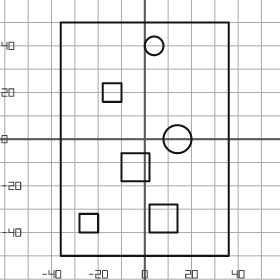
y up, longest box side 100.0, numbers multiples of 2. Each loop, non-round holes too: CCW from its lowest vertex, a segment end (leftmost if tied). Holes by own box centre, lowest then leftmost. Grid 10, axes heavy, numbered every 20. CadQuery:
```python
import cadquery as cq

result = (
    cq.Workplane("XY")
    .moveTo(-36.0, -50.0)
    .lineTo(36.0, -50.0)
    .lineTo(36.0, 50.0)
    .lineTo(-36.0, 50.0)
    .close()
    .moveTo(-28.0, -40.0)
    .lineTo(-20.0, -40.0)
    .lineTo(-20.0, -32.0)
    .lineTo(-28.0, -32.0)
    .close()
    .moveTo(2.0, -40.0)
    .lineTo(14.0, -40.0)
    .lineTo(14.0, -28.0)
    .lineTo(2.0, -28.0)
    .close()
    .moveTo(-10.0, -18.0)
    .lineTo(2.0, -18.0)
    .lineTo(2.0, -6.0)
    .lineTo(-10.0, -6.0)
    .close()
    .moveTo(14.0, 0.0)
    .circle(6.0)
    .moveTo(-18.0, 16.0)
    .lineTo(-10.0, 16.0)
    .lineTo(-10.0, 24.0)
    .lineTo(-18.0, 24.0)
    .close()
    .moveTo(4.0, 40.0)
    .circle(4.0)
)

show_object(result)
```